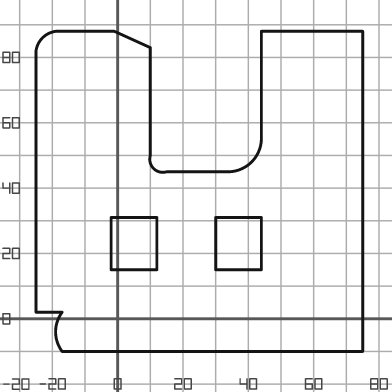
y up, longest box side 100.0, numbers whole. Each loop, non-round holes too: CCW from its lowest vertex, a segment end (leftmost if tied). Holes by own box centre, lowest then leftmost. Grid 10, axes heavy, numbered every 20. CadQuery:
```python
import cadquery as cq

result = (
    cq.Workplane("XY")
    .moveTo(-17.0, -10.0)
    .lineTo(75.0, -10.0)
    .lineTo(75.0, 88.0)
    .lineTo(44.0, 88.0)
    .lineTo(44.0, 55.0)
    .threePointArc((41.0, 48.0), (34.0, 45.0))
    .lineTo(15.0, 45.0)
    .threePointArc((11.0, 46.0), (10.0, 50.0))
    .lineTo(10.0, 83.0)
    .lineTo(-1.0, 88.0)
    .lineTo(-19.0, 88.0)
    .threePointArc((-23.0, 86.0), (-25.0, 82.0))
    .lineTo(-25.0, 2.0)
    .lineTo(-17.0, 2.0)
    .threePointArc((-19.0, -4.0), (-17.0, -10.0))
    .close()
    .moveTo(-2.0, 15.0)
    .lineTo(12.0, 15.0)
    .lineTo(12.0, 31.0)
    .lineTo(-2.0, 31.0)
    .close()
    .moveTo(30.0, 15.0)
    .lineTo(44.0, 15.0)
    .lineTo(44.0, 31.0)
    .lineTo(30.0, 31.0)
    .close()
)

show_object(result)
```